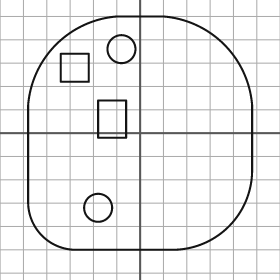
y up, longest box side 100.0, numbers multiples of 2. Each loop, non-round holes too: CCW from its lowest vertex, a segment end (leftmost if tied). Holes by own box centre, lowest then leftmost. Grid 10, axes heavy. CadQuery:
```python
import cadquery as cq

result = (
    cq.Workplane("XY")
    .moveTo(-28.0, -50.0)
    .lineTo(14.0, -50.0)
    .threePointArc((38.0, -40.0), (48.0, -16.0))
    .lineTo(48.0, 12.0)
    .threePointArc((36.0, 38.0), (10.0, 50.0))
    .lineTo(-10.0, 50.0)
    .threePointArc((-36.0, 38.0), (-48.0, 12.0))
    .lineTo(-48.0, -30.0)
    .threePointArc((-42.0, -44.0), (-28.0, -50.0))
    .close()
    .moveTo(-18.0, -32.0)
    .circle(6.0)
    .moveTo(-18.0, -2.0)
    .lineTo(-6.0, -2.0)
    .lineTo(-6.0, 14.0)
    .lineTo(-18.0, 14.0)
    .close()
    .moveTo(-34.0, 22.0)
    .lineTo(-22.0, 22.0)
    .lineTo(-22.0, 34.0)
    .lineTo(-34.0, 34.0)
    .close()
    .moveTo(-8.0, 36.0)
    .circle(6.0)
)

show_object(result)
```